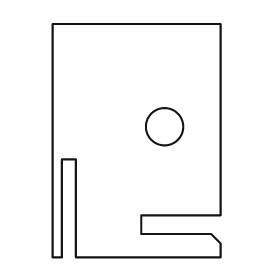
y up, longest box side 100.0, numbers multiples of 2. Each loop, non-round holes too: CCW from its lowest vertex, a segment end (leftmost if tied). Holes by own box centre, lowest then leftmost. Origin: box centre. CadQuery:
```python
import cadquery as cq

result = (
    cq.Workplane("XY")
    .moveTo(-36.0, -50.0)
    .lineTo(-32.0, -50.0)
    .lineTo(-32.0, -8.0)
    .lineTo(-26.0, -8.0)
    .lineTo(-26.0, -50.0)
    .lineTo(36.0, -50.0)
    .lineTo(36.0, -44.0)
    .lineTo(32.0, -40.0)
    .lineTo(2.0, -40.0)
    .lineTo(2.0, -32.0)
    .lineTo(36.0, -32.0)
    .lineTo(36.0, 50.0)
    .lineTo(-36.0, 50.0)
    .close()
    .moveTo(12.0, 6.0)
    .circle(8.0)
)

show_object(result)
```